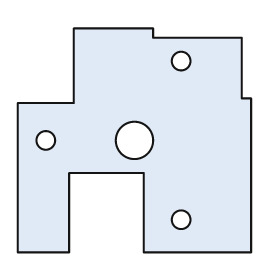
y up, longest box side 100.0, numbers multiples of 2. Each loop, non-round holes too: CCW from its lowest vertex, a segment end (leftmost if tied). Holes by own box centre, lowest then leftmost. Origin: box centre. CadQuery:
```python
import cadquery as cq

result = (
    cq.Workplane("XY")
    .moveTo(-50.0, -48.0)
    .lineTo(-28.0, -48.0)
    .lineTo(-28.0, -14.0)
    .lineTo(4.0, -14.0)
    .lineTo(4.0, -48.0)
    .lineTo(50.0, -48.0)
    .lineTo(50.0, 18.0)
    .lineTo(46.0, 18.0)
    .lineTo(46.0, 44.0)
    .lineTo(8.0, 44.0)
    .lineTo(8.0, 48.0)
    .lineTo(-26.0, 48.0)
    .lineTo(-26.0, 16.0)
    .lineTo(-50.0, 16.0)
    .close()
    .moveTo(20.0, -34.0)
    .circle(4.0)
    .moveTo(-38.0, 0.0)
    .circle(4.0)
    .moveTo(0.0, 0.0)
    .circle(8.0)
    .moveTo(20.0, 34.0)
    .circle(4.0)
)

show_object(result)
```